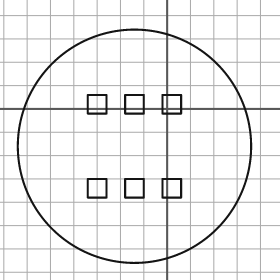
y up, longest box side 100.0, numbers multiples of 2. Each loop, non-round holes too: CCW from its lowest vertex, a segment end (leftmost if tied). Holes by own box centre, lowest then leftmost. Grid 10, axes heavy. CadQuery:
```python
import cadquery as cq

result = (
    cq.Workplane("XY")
    .moveTo(-14.0, -16.0)
    .circle(50.0)
    .moveTo(-34.0, -38.0)
    .lineTo(-26.0, -38.0)
    .lineTo(-26.0, -30.0)
    .lineTo(-34.0, -30.0)
    .close()
    .moveTo(-18.0, -38.0)
    .lineTo(-10.0, -38.0)
    .lineTo(-10.0, -30.0)
    .lineTo(-18.0, -30.0)
    .close()
    .moveTo(-2.0, -38.0)
    .lineTo(6.0, -38.0)
    .lineTo(6.0, -30.0)
    .lineTo(-2.0, -30.0)
    .close()
    .moveTo(-34.0, -2.0)
    .lineTo(-26.0, -2.0)
    .lineTo(-26.0, 6.0)
    .lineTo(-34.0, 6.0)
    .close()
    .moveTo(-18.0, -2.0)
    .lineTo(-10.0, -2.0)
    .lineTo(-10.0, 6.0)
    .lineTo(-18.0, 6.0)
    .close()
    .moveTo(-2.0, -2.0)
    .lineTo(6.0, -2.0)
    .lineTo(6.0, 6.0)
    .lineTo(-2.0, 6.0)
    .close()
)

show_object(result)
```